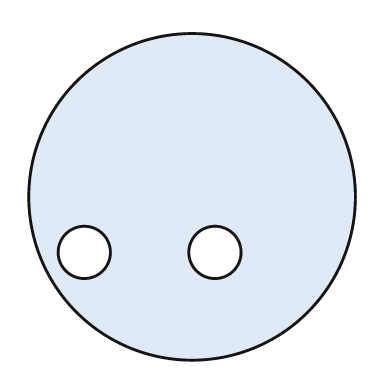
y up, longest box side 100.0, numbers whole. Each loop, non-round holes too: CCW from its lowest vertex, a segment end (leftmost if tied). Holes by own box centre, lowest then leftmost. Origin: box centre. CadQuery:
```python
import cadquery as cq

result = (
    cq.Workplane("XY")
    .moveTo(0.0, 0.0)
    .circle(50.0)
    .moveTo(-33.0, -17.0)
    .circle(8.0)
    .moveTo(7.0, -17.0)
    .circle(8.0)
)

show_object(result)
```